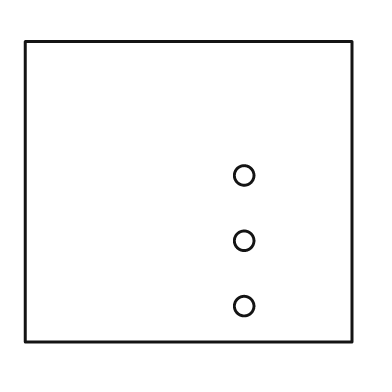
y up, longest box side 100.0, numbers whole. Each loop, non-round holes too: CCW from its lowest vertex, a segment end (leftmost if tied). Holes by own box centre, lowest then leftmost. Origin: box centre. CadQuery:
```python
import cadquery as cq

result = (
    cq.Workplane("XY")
    .moveTo(-50.0, -46.0)
    .lineTo(50.0, -46.0)
    .lineTo(50.0, 46.0)
    .lineTo(-50.0, 46.0)
    .close()
    .moveTo(17.0, -35.0)
    .circle(3.0)
    .moveTo(17.0, -15.0)
    .circle(3.0)
    .moveTo(17.0, 5.0)
    .circle(3.0)
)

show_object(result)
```